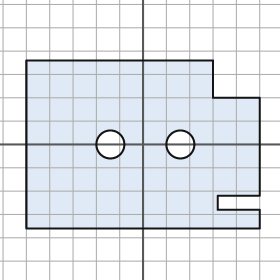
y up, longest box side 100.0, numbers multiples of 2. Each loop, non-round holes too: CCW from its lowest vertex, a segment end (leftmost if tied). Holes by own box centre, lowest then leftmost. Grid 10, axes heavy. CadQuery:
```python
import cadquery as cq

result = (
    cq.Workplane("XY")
    .moveTo(-50.0, -36.0)
    .lineTo(50.0, -36.0)
    .lineTo(50.0, -28.0)
    .lineTo(32.0, -28.0)
    .lineTo(32.0, -22.0)
    .lineTo(50.0, -22.0)
    .lineTo(50.0, 20.0)
    .lineTo(30.0, 20.0)
    .lineTo(30.0, 36.0)
    .lineTo(-50.0, 36.0)
    .close()
    .moveTo(-14.0, 0.0)
    .circle(6.0)
    .moveTo(16.0, 0.0)
    .circle(6.0)
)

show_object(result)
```